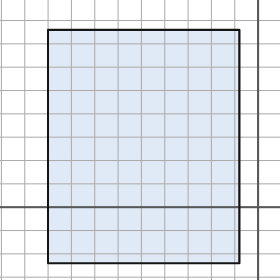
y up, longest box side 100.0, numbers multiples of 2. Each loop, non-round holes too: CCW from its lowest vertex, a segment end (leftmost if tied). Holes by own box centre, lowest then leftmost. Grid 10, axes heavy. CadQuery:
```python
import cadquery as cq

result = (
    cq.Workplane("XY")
    .moveTo(-90.0, -24.0)
    .lineTo(-8.0, -24.0)
    .lineTo(-8.0, 76.0)
    .lineTo(-90.0, 76.0)
    .close()
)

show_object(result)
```